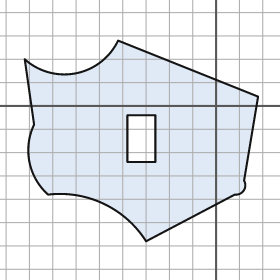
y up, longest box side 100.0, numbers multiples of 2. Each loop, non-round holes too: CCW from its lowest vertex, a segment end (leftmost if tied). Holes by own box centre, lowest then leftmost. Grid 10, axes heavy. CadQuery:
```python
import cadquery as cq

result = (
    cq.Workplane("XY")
    .moveTo(-30.0, -58.0)
    .lineTo(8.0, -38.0)
    .threePointArc((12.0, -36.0), (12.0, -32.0))
    .lineTo(18.0, 4.0)
    .lineTo(-42.0, 28.0)
    .threePointArc((-60.0, 14.0), (-82.0, 20.0))
    .lineTo(-78.0, -8.0)
    .threePointArc((-80.0, -24.0), (-72.0, -38.0))
    .threePointArc((-48.0, -42.0), (-30.0, -58.0))
    .close()
    .moveTo(-38.0, -24.0)
    .lineTo(-26.0, -24.0)
    .lineTo(-26.0, -4.0)
    .lineTo(-38.0, -4.0)
    .close()
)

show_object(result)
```